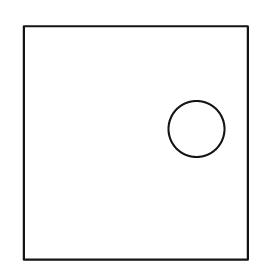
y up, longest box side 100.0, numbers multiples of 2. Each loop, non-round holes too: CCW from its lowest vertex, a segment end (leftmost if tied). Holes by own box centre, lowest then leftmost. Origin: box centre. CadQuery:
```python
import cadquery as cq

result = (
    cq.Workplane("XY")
    .moveTo(-48.0, -50.0)
    .lineTo(48.0, -50.0)
    .lineTo(48.0, 50.0)
    .lineTo(-48.0, 50.0)
    .close()
    .moveTo(26.0, 6.0)
    .circle(12.0)
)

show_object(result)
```